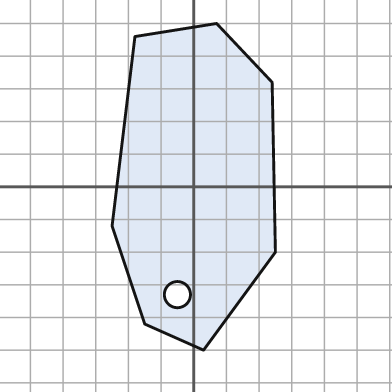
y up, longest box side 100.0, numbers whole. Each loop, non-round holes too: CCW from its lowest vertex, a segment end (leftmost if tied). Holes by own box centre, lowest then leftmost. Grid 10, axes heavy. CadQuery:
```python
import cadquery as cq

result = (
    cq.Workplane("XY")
    .moveTo(3.0, -50.0)
    .lineTo(25.0, -20.0)
    .lineTo(24.0, 32.0)
    .lineTo(7.0, 50.0)
    .lineTo(-18.0, 46.0)
    .lineTo(-25.0, -12.0)
    .lineTo(-15.0, -42.0)
    .close()
    .moveTo(-5.0, -33.0)
    .circle(4.0)
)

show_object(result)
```